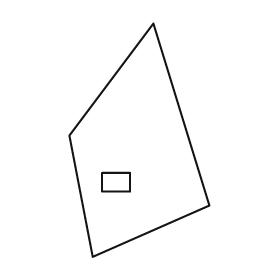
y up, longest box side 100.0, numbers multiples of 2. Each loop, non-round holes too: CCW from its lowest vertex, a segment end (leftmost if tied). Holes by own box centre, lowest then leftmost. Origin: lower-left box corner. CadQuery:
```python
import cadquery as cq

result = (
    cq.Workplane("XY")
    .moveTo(10.0, 0.0)
    .lineTo(60.0, 22.0)
    .lineTo(36.0, 100.0)
    .lineTo(0.0, 52.0)
    .close()
    .moveTo(14.0, 28.0)
    .lineTo(26.0, 28.0)
    .lineTo(26.0, 36.0)
    .lineTo(14.0, 36.0)
    .close()
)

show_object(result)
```